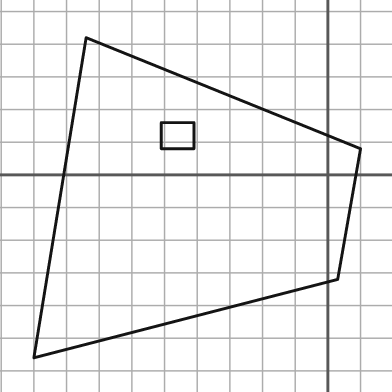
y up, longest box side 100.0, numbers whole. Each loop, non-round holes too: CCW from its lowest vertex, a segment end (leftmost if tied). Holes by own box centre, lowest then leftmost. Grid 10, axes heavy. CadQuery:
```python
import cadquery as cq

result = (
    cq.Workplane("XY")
    .moveTo(-90.0, -56.0)
    .lineTo(3.0, -32.0)
    .lineTo(10.0, 8.0)
    .lineTo(-74.0, 42.0)
    .close()
    .moveTo(-51.0, 8.0)
    .lineTo(-41.0, 8.0)
    .lineTo(-41.0, 16.0)
    .lineTo(-51.0, 16.0)
    .close()
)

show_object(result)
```